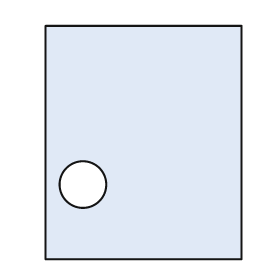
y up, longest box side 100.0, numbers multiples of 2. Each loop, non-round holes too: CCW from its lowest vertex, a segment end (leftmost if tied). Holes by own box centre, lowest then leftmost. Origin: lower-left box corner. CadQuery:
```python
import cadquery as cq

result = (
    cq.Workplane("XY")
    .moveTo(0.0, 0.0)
    .lineTo(84.0, 0.0)
    .lineTo(84.0, 100.0)
    .lineTo(0.0, 100.0)
    .close()
    .moveTo(16.0, 32.0)
    .circle(10.0)
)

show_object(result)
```